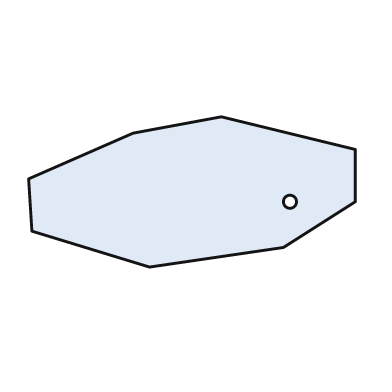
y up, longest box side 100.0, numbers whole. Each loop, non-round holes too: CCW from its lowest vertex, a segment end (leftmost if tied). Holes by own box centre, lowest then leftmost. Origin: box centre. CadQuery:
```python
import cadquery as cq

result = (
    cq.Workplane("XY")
    .moveTo(-13.0, -23.0)
    .lineTo(28.0, -17.0)
    .lineTo(50.0, -3.0)
    .lineTo(50.0, 13.0)
    .lineTo(9.0, 23.0)
    .lineTo(-18.0, 18.0)
    .lineTo(-50.0, 4.0)
    .lineTo(-49.0, -12.0)
    .close()
    .moveTo(30.0, -3.0)
    .circle(2.0)
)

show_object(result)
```